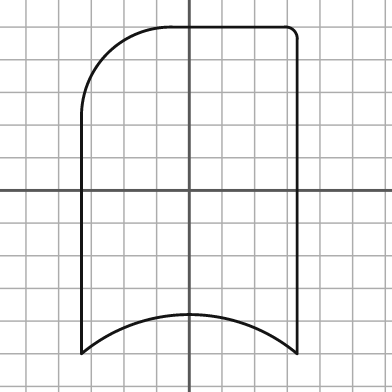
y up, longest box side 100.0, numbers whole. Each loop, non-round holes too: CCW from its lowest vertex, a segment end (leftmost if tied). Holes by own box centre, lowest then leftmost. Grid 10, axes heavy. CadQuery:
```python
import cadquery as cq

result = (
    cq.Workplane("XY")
    .moveTo(-33.0, -50.0)
    .threePointArc((0.0, -38.0), (33.0, -50.0))
    .lineTo(33.0, 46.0)
    .threePointArc((32.0, 49.0), (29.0, 50.0))
    .lineTo(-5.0, 50.0)
    .threePointArc((-25.0, 42.0), (-33.0, 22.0))
    .close()
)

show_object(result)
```